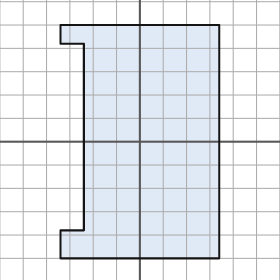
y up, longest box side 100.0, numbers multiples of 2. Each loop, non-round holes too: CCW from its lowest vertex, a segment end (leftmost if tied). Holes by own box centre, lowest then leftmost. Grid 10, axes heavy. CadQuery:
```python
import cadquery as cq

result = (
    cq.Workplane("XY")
    .moveTo(-34.0, -50.0)
    .lineTo(34.0, -50.0)
    .lineTo(34.0, 50.0)
    .lineTo(-34.0, 50.0)
    .lineTo(-34.0, 42.0)
    .lineTo(-24.0, 42.0)
    .lineTo(-24.0, -38.0)
    .lineTo(-34.0, -38.0)
    .close()
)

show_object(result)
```